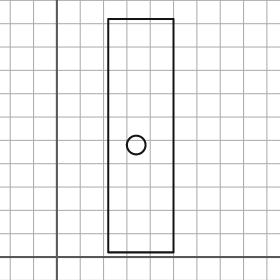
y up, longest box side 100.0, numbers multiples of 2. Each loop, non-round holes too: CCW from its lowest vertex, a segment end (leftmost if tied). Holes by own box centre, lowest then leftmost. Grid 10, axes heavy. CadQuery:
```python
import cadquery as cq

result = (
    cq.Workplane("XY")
    .moveTo(22.0, 2.0)
    .lineTo(50.0, 2.0)
    .lineTo(50.0, 102.0)
    .lineTo(22.0, 102.0)
    .close()
    .moveTo(34.0, 48.0)
    .circle(4.0)
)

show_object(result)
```